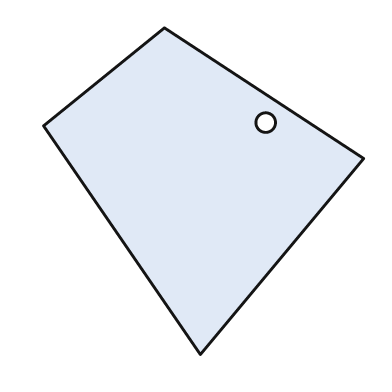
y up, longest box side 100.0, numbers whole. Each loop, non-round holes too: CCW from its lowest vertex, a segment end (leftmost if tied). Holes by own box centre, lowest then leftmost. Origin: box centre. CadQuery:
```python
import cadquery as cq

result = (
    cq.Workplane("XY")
    .moveTo(-1.0, -50.0)
    .lineTo(49.0, 10.0)
    .lineTo(-12.0, 50.0)
    .lineTo(-49.0, 20.0)
    .close()
    .moveTo(19.0, 21.0)
    .circle(3.0)
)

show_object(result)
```